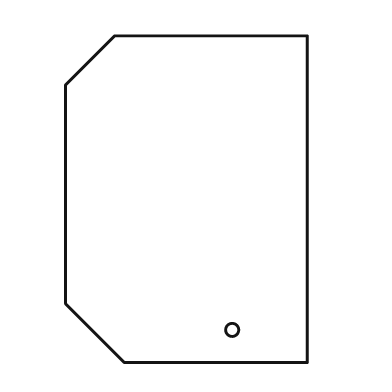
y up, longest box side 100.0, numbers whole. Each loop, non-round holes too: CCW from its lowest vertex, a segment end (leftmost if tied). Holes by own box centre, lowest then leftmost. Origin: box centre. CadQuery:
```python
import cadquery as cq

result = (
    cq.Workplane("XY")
    .moveTo(-19.0, -50.0)
    .lineTo(37.0, -50.0)
    .lineTo(37.0, 50.0)
    .lineTo(-22.0, 50.0)
    .lineTo(-37.0, 35.0)
    .lineTo(-37.0, -32.0)
    .close()
    .moveTo(14.0, -40.0)
    .circle(2.0)
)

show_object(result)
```